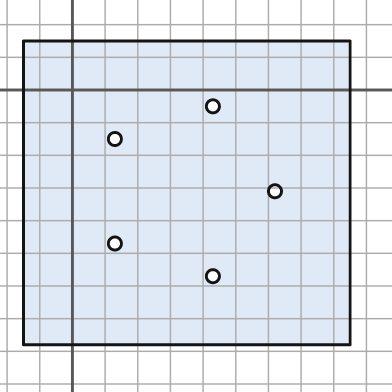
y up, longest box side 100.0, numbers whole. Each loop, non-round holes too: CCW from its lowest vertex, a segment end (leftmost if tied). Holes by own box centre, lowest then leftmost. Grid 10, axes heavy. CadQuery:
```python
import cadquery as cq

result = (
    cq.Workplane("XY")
    .moveTo(-15.0, -78.0)
    .lineTo(85.0, -78.0)
    .lineTo(85.0, 15.0)
    .lineTo(-15.0, 15.0)
    .close()
    .moveTo(43.0, -57.0)
    .circle(2.0)
    .moveTo(13.0, -47.0)
    .circle(2.0)
    .moveTo(62.0, -31.0)
    .circle(2.0)
    .moveTo(13.0, -15.0)
    .circle(2.0)
    .moveTo(43.0, -5.0)
    .circle(2.0)
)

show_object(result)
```